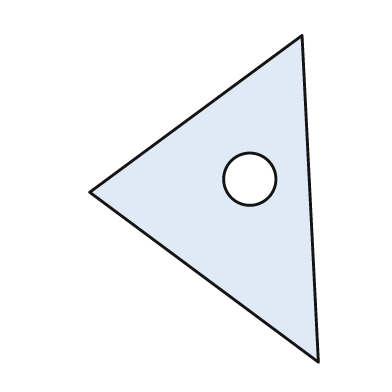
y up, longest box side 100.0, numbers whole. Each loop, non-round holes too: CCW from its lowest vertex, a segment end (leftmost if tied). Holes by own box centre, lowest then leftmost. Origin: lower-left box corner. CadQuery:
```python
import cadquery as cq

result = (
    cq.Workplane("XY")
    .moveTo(70.0, 0.0)
    .lineTo(65.0, 100.0)
    .lineTo(0.0, 52.0)
    .close()
    .moveTo(49.0, 56.0)
    .circle(8.0)
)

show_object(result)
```